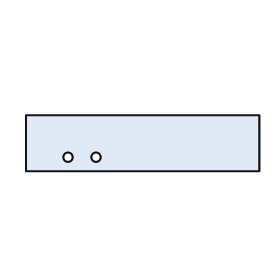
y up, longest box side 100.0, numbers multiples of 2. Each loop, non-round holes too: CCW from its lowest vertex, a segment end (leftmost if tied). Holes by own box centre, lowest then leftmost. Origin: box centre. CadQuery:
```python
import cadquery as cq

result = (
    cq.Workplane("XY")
    .moveTo(-50.0, -12.0)
    .lineTo(50.0, -12.0)
    .lineTo(50.0, 12.0)
    .lineTo(-50.0, 12.0)
    .close()
    .moveTo(-32.0, -6.0)
    .circle(2.0)
    .moveTo(-20.0, -6.0)
    .circle(2.0)
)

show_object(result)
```